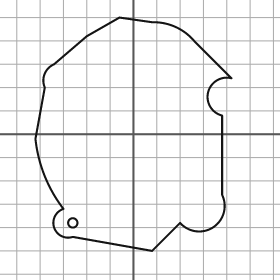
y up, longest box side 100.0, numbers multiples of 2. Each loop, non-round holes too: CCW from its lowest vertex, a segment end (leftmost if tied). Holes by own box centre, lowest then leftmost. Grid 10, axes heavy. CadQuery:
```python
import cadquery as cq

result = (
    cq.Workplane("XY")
    .moveTo(8.0, -50.0)
    .lineTo(20.0, -38.0)
    .threePointArc((34.0, -40.0), (38.0, -26.0))
    .lineTo(38.0, 8.0)
    .threePointArc((32.0, 18.0), (42.0, 24.0))
    .lineTo(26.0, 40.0)
    .threePointArc((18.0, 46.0), (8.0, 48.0))
    .lineTo(-6.0, 50.0)
    .lineTo(-20.0, 42.0)
    .lineTo(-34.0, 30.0)
    .threePointArc((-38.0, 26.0), (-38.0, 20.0))
    .lineTo(-42.0, -2.0)
    .threePointArc((-38.0, -18.0), (-30.0, -32.0))
    .threePointArc((-34.0, -40.0), (-26.0, -44.0))
    .close()
    .moveTo(-26.0, -38.0)
    .circle(2.0)
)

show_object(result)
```